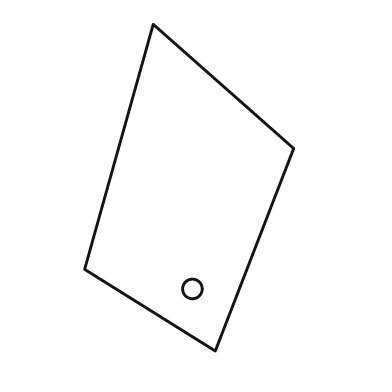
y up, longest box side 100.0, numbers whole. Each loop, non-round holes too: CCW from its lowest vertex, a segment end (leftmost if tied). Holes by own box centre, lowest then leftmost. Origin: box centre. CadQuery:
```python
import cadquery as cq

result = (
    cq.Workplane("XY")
    .moveTo(8.0, -50.0)
    .lineTo(32.0, 12.0)
    .lineTo(-11.0, 50.0)
    .lineTo(-32.0, -25.0)
    .close()
    .moveTo(1.0, -31.0)
    .circle(3.0)
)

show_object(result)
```